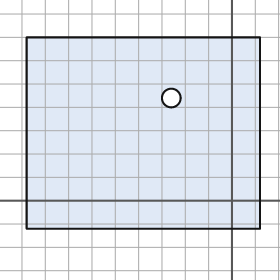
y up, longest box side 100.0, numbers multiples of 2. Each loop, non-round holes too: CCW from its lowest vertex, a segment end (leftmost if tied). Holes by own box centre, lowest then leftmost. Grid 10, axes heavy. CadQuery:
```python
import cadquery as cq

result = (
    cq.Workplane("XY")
    .moveTo(-88.0, -12.0)
    .lineTo(12.0, -12.0)
    .lineTo(12.0, 70.0)
    .lineTo(-88.0, 70.0)
    .close()
    .moveTo(-26.0, 44.0)
    .circle(4.0)
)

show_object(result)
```